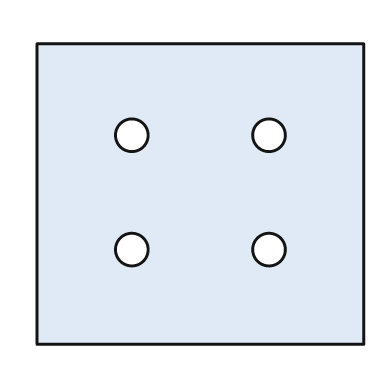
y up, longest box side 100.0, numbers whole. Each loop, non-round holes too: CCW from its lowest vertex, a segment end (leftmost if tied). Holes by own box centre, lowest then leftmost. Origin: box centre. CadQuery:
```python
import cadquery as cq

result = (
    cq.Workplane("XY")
    .moveTo(-50.0, -46.0)
    .lineTo(50.0, -46.0)
    .lineTo(50.0, 46.0)
    .lineTo(-50.0, 46.0)
    .close()
    .moveTo(-21.0, -17.0)
    .circle(5.0)
    .moveTo(21.0, -17.0)
    .circle(5.0)
    .moveTo(-21.0, 18.0)
    .circle(5.0)
    .moveTo(21.0, 18.0)
    .circle(5.0)
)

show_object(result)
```